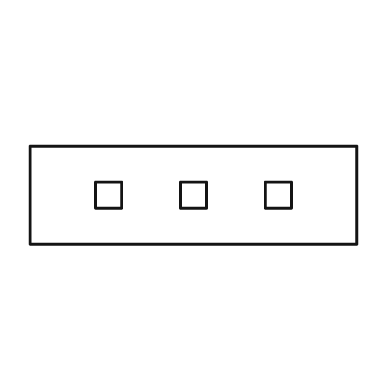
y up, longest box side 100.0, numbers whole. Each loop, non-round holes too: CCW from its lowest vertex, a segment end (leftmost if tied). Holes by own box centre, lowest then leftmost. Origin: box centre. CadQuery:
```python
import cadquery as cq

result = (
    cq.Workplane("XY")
    .moveTo(-50.0, -15.0)
    .lineTo(50.0, -15.0)
    .lineTo(50.0, 15.0)
    .lineTo(-50.0, 15.0)
    .close()
    .moveTo(-30.0, -4.0)
    .lineTo(-22.0, -4.0)
    .lineTo(-22.0, 4.0)
    .lineTo(-30.0, 4.0)
    .close()
    .moveTo(-4.0, -4.0)
    .lineTo(4.0, -4.0)
    .lineTo(4.0, 4.0)
    .lineTo(-4.0, 4.0)
    .close()
    .moveTo(22.0, -4.0)
    .lineTo(30.0, -4.0)
    .lineTo(30.0, 4.0)
    .lineTo(22.0, 4.0)
    .close()
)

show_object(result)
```